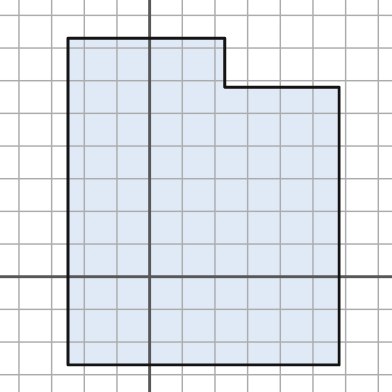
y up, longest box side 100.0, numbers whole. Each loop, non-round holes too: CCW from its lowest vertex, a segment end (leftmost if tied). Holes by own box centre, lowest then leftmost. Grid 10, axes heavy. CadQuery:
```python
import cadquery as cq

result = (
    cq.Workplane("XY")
    .moveTo(-25.0, -27.0)
    .lineTo(58.0, -27.0)
    .lineTo(58.0, 58.0)
    .lineTo(23.0, 58.0)
    .lineTo(23.0, 73.0)
    .lineTo(-25.0, 73.0)
    .close()
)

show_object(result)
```